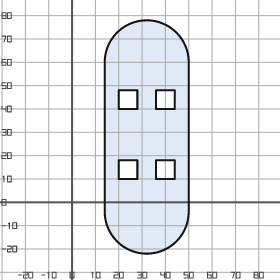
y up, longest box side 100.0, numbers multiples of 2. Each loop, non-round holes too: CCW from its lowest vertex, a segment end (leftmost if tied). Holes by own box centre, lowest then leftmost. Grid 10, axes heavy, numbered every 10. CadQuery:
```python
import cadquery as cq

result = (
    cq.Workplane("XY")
    .moveTo(14.0, -4.0)
    .threePointArc((32.0, -22.0), (50.0, -4.0))
    .lineTo(50.0, 60.0)
    .threePointArc((32.0, 78.0), (14.0, 60.0))
    .close()
    .moveTo(20.0, 10.0)
    .lineTo(28.0, 10.0)
    .lineTo(28.0, 18.0)
    .lineTo(20.0, 18.0)
    .close()
    .moveTo(36.0, 10.0)
    .lineTo(44.0, 10.0)
    .lineTo(44.0, 18.0)
    .lineTo(36.0, 18.0)
    .close()
    .moveTo(20.0, 40.0)
    .lineTo(28.0, 40.0)
    .lineTo(28.0, 48.0)
    .lineTo(20.0, 48.0)
    .close()
    .moveTo(36.0, 40.0)
    .lineTo(44.0, 40.0)
    .lineTo(44.0, 48.0)
    .lineTo(36.0, 48.0)
    .close()
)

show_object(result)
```